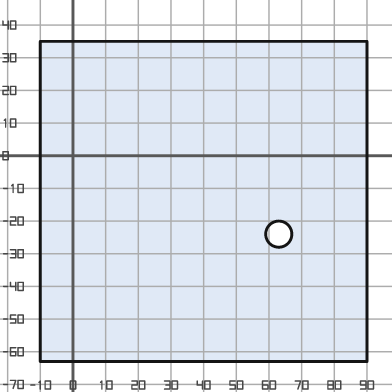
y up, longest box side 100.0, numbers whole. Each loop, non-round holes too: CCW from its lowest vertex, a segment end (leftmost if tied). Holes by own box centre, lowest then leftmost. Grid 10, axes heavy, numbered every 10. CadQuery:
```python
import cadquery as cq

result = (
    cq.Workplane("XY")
    .moveTo(-10.0, -63.0)
    .lineTo(90.0, -63.0)
    .lineTo(90.0, 35.0)
    .lineTo(-10.0, 35.0)
    .close()
    .moveTo(63.0, -24.0)
    .circle(4.0)
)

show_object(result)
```